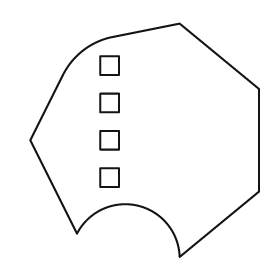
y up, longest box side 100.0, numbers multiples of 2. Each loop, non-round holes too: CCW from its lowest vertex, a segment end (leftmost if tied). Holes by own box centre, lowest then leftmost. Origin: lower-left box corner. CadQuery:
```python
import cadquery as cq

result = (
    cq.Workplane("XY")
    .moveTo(64.0, 0.0)
    .lineTo(98.0, 28.0)
    .lineTo(98.0, 72.0)
    .lineTo(64.0, 100.0)
    .lineTo(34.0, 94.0)
    .threePointArc((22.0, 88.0), (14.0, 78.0))
    .lineTo(0.0, 50.0)
    .lineTo(20.0, 10.0)
    .threePointArc((46.0, 22.0), (64.0, 0.0))
    .close()
    .moveTo(30.0, 30.0)
    .lineTo(38.0, 30.0)
    .lineTo(38.0, 38.0)
    .lineTo(30.0, 38.0)
    .close()
    .moveTo(30.0, 46.0)
    .lineTo(38.0, 46.0)
    .lineTo(38.0, 54.0)
    .lineTo(30.0, 54.0)
    .close()
    .moveTo(30.0, 62.0)
    .lineTo(38.0, 62.0)
    .lineTo(38.0, 70.0)
    .lineTo(30.0, 70.0)
    .close()
    .moveTo(30.0, 78.0)
    .lineTo(38.0, 78.0)
    .lineTo(38.0, 86.0)
    .lineTo(30.0, 86.0)
    .close()
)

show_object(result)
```